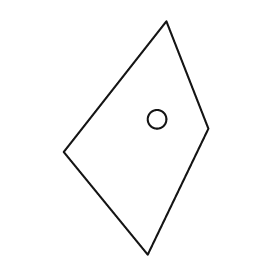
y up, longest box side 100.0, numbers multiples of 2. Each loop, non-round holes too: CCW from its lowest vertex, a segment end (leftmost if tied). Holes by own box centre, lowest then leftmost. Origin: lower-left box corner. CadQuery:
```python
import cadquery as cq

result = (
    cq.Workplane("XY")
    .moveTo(36.0, 0.0)
    .lineTo(62.0, 54.0)
    .lineTo(44.0, 100.0)
    .lineTo(0.0, 44.0)
    .close()
    .moveTo(40.0, 58.0)
    .circle(4.0)
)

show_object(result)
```